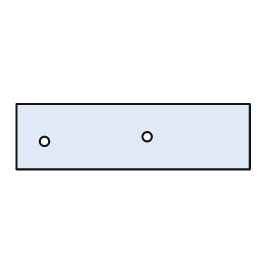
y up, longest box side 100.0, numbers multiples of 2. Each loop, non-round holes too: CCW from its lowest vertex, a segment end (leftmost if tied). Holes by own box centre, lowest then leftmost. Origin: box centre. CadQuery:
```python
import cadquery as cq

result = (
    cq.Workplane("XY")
    .moveTo(-50.0, -14.0)
    .lineTo(50.0, -14.0)
    .lineTo(50.0, 14.0)
    .lineTo(-50.0, 14.0)
    .close()
    .moveTo(-38.0, -2.0)
    .circle(2.0)
    .moveTo(6.0, 0.0)
    .circle(2.0)
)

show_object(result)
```